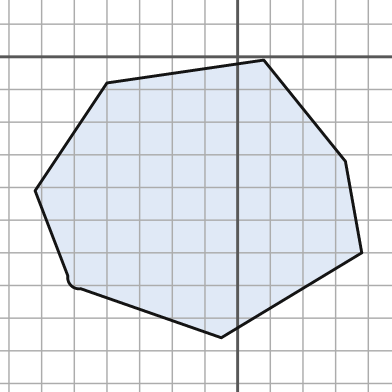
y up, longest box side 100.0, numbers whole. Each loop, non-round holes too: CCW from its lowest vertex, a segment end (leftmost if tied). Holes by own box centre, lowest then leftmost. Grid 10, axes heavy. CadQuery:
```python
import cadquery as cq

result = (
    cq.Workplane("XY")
    .moveTo(-5.0, -86.0)
    .lineTo(38.0, -60.0)
    .lineTo(33.0, -32.0)
    .lineTo(8.0, -1.0)
    .lineTo(-40.0, -8.0)
    .lineTo(-62.0, -41.0)
    .lineTo(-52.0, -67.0)
    .threePointArc((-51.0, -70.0), (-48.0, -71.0))
    .close()
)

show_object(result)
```